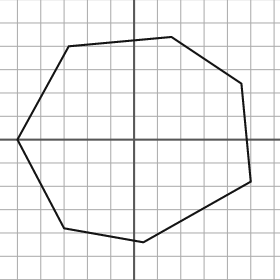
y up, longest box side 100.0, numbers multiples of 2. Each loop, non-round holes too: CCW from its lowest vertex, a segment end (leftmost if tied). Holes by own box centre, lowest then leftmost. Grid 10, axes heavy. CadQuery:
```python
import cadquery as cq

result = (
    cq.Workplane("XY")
    .moveTo(4.0, -44.0)
    .lineTo(50.0, -18.0)
    .lineTo(46.0, 24.0)
    .lineTo(16.0, 44.0)
    .lineTo(-28.0, 40.0)
    .lineTo(-50.0, 0.0)
    .lineTo(-30.0, -38.0)
    .close()
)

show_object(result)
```